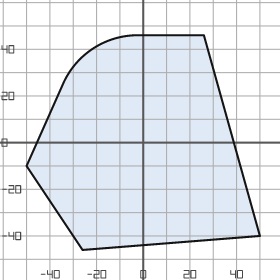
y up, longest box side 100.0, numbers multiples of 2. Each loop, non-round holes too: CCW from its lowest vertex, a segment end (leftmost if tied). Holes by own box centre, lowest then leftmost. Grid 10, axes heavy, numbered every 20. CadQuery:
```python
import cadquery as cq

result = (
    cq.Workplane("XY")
    .moveTo(-26.0, -46.0)
    .lineTo(50.0, -40.0)
    .lineTo(26.0, 46.0)
    .lineTo(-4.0, 46.0)
    .threePointArc((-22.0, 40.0), (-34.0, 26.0))
    .lineTo(-50.0, -10.0)
    .close()
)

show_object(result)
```